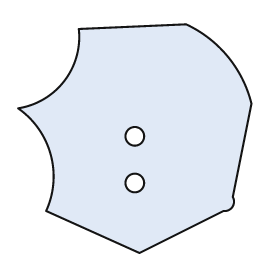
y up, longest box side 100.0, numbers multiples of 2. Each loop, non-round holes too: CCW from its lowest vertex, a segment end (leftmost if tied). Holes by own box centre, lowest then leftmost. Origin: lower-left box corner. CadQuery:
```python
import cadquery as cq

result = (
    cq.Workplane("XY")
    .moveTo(52.0, 0.0)
    .lineTo(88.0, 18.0)
    .threePointArc((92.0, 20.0), (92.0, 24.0))
    .lineTo(100.0, 64.0)
    .threePointArc((90.0, 84.0), (72.0, 98.0))
    .lineTo(26.0, 96.0)
    .threePointArc((20.0, 74.0), (0.0, 62.0))
    .threePointArc((14.0, 42.0), (12.0, 18.0))
    .close()
    .moveTo(50.0, 30.0)
    .circle(4.0)
    .moveTo(50.0, 50.0)
    .circle(4.0)
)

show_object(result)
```